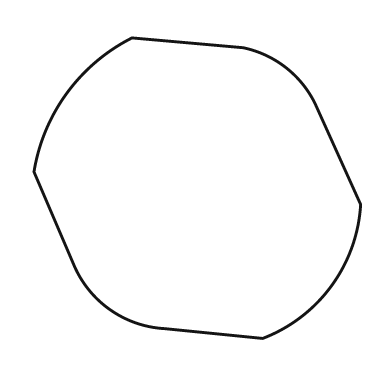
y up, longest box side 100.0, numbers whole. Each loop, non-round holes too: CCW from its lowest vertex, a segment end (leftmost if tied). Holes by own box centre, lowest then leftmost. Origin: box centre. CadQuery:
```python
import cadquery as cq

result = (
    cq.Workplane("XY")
    .moveTo(20.0, -46.0)
    .threePointArc((41.0, -30.0), (50.0, -5.0))
    .lineTo(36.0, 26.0)
    .threePointArc((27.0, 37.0), (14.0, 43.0))
    .lineTo(-20.0, 46.0)
    .threePointArc((-40.0, 29.0), (-50.0, 5.0))
    .lineTo(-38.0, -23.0)
    .threePointArc((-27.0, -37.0), (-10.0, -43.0))
    .close()
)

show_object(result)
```